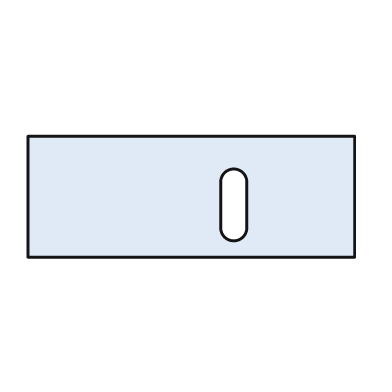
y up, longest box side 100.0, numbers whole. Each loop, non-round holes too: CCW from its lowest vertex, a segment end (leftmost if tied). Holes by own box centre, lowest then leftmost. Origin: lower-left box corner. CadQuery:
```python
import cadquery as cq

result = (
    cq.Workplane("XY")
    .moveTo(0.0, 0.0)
    .lineTo(100.0, 0.0)
    .lineTo(100.0, 37.0)
    .lineTo(0.0, 37.0)
    .close()
    .moveTo(59.0, 9.0)
    .threePointArc((63.0, 5.0), (67.0, 9.0))
    .lineTo(67.0, 23.0)
    .threePointArc((63.0, 27.0), (59.0, 23.0))
    .close()
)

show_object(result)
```